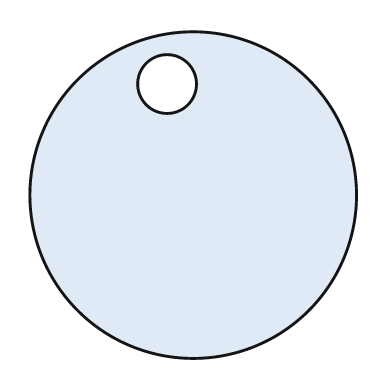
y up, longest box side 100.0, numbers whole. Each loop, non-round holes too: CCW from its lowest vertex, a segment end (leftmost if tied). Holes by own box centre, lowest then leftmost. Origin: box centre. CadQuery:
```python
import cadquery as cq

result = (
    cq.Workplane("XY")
    .moveTo(0.0, 0.0)
    .circle(50.0)
    .moveTo(-8.0, 34.0)
    .circle(9.0)
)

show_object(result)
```